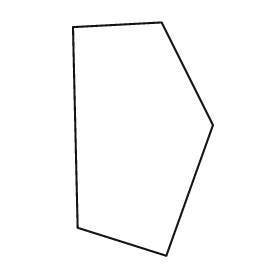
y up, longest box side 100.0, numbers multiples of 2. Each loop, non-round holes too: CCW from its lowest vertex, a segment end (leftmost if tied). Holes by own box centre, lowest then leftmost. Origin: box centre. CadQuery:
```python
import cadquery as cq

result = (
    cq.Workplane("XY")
    .moveTo(10.0, -50.0)
    .lineTo(30.0, 6.0)
    .lineTo(8.0, 50.0)
    .lineTo(-30.0, 48.0)
    .lineTo(-28.0, -38.0)
    .close()
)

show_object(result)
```